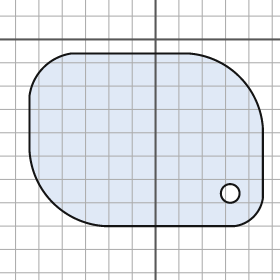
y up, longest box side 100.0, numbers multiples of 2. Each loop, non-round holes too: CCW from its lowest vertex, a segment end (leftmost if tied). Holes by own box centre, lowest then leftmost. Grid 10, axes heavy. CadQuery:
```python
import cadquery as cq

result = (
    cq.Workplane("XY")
    .moveTo(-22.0, -80.0)
    .lineTo(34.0, -80.0)
    .threePointArc((42.0, -76.0), (46.0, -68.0))
    .lineTo(46.0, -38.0)
    .threePointArc((36.0, -16.0), (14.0, -6.0))
    .lineTo(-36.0, -6.0)
    .threePointArc((-48.0, -12.0), (-54.0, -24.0))
    .lineTo(-54.0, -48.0)
    .threePointArc((-44.0, -70.0), (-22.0, -80.0))
    .close()
    .moveTo(32.0, -66.0)
    .circle(4.0)
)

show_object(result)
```